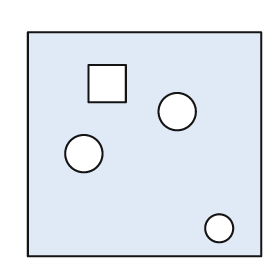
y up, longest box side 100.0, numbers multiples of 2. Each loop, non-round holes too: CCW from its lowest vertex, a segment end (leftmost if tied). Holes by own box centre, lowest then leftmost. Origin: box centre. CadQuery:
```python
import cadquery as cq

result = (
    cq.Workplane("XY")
    .moveTo(-50.0, -48.0)
    .lineTo(50.0, -48.0)
    .lineTo(50.0, 48.0)
    .lineTo(-50.0, 48.0)
    .close()
    .moveTo(32.0, -36.0)
    .circle(6.0)
    .moveTo(-26.0, -4.0)
    .circle(8.0)
    .moveTo(14.0, 14.0)
    .circle(8.0)
    .moveTo(-24.0, 18.0)
    .lineTo(-8.0, 18.0)
    .lineTo(-8.0, 34.0)
    .lineTo(-24.0, 34.0)
    .close()
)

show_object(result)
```